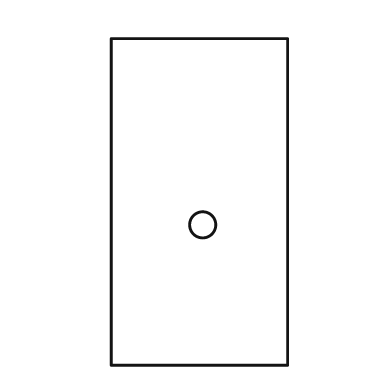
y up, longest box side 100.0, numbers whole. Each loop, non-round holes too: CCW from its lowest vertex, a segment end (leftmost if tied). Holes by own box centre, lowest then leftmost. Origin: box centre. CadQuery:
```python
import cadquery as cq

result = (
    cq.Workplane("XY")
    .moveTo(-27.0, -50.0)
    .lineTo(27.0, -50.0)
    .lineTo(27.0, 50.0)
    .lineTo(-27.0, 50.0)
    .close()
    .moveTo(1.0, -7.0)
    .circle(4.0)
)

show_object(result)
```